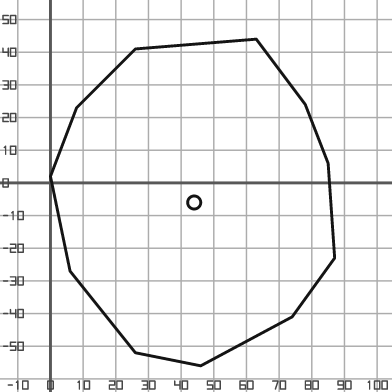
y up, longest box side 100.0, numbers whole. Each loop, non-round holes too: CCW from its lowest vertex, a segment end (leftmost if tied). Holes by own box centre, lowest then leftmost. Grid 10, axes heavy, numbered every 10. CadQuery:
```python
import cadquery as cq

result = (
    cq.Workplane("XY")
    .moveTo(46.0, -56.0)
    .lineTo(74.0, -41.0)
    .lineTo(87.0, -23.0)
    .lineTo(85.0, 6.0)
    .lineTo(78.0, 24.0)
    .lineTo(63.0, 44.0)
    .lineTo(26.0, 41.0)
    .lineTo(8.0, 23.0)
    .lineTo(0.0, 2.0)
    .lineTo(6.0, -27.0)
    .lineTo(26.0, -52.0)
    .close()
    .moveTo(44.0, -6.0)
    .circle(2.0)
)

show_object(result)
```